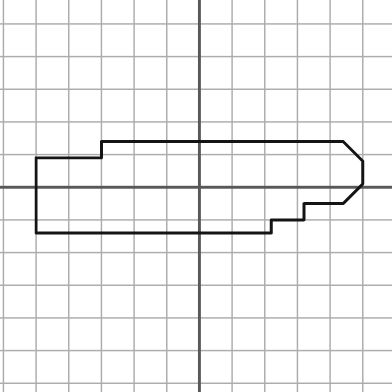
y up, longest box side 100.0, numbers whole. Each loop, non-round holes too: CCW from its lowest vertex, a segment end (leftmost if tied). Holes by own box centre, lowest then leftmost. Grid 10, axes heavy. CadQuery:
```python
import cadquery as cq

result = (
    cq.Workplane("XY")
    .moveTo(-50.0, -14.0)
    .lineTo(22.0, -14.0)
    .lineTo(22.0, -10.0)
    .lineTo(32.0, -10.0)
    .lineTo(32.0, -5.0)
    .lineTo(44.0, -5.0)
    .lineTo(50.0, 1.0)
    .lineTo(50.0, 8.0)
    .lineTo(44.0, 14.0)
    .lineTo(-30.0, 14.0)
    .lineTo(-30.0, 9.0)
    .lineTo(-50.0, 9.0)
    .close()
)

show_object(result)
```